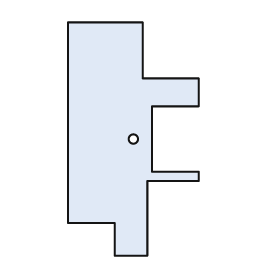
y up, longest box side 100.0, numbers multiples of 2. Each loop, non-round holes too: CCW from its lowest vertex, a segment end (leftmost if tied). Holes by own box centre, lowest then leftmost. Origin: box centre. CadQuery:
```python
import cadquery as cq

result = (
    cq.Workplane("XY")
    .moveTo(-8.0, -50.0)
    .lineTo(6.0, -50.0)
    .lineTo(6.0, -18.0)
    .lineTo(28.0, -18.0)
    .lineTo(28.0, -14.0)
    .lineTo(8.0, -14.0)
    .lineTo(8.0, 14.0)
    .lineTo(28.0, 14.0)
    .lineTo(28.0, 26.0)
    .lineTo(4.0, 26.0)
    .lineTo(4.0, 50.0)
    .lineTo(-28.0, 50.0)
    .lineTo(-28.0, -36.0)
    .lineTo(-8.0, -36.0)
    .close()
    .moveTo(0.0, 0.0)
    .circle(2.0)
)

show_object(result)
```